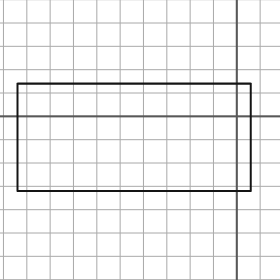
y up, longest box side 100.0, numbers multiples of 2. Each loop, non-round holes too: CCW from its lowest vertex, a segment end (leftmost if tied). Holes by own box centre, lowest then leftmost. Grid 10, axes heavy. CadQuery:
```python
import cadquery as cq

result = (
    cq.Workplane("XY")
    .moveTo(-94.0, -32.0)
    .lineTo(6.0, -32.0)
    .lineTo(6.0, 14.0)
    .lineTo(-94.0, 14.0)
    .close()
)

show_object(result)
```